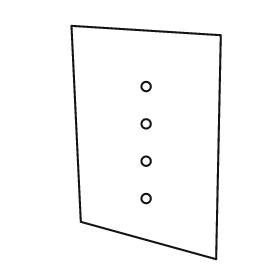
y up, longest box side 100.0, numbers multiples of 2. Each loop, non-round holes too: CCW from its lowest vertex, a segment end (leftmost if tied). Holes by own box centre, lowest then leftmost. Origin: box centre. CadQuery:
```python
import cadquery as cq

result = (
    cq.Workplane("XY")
    .moveTo(30.0, -50.0)
    .lineTo(32.0, 46.0)
    .lineTo(-32.0, 50.0)
    .lineTo(-28.0, -34.0)
    .close()
    .moveTo(0.0, -24.0)
    .circle(2.0)
    .moveTo(0.0, -8.0)
    .circle(2.0)
    .moveTo(0.0, 8.0)
    .circle(2.0)
    .moveTo(0.0, 24.0)
    .circle(2.0)
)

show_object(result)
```